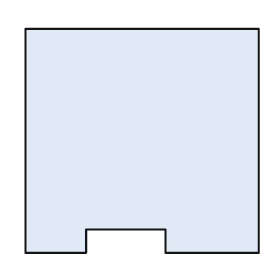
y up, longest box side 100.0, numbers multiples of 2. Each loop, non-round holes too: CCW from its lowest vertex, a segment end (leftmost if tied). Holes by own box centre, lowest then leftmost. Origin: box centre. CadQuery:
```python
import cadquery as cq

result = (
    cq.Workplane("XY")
    .moveTo(-50.0, -48.0)
    .lineTo(-24.0, -48.0)
    .lineTo(-24.0, -38.0)
    .lineTo(10.0, -38.0)
    .lineTo(10.0, -48.0)
    .lineTo(50.0, -48.0)
    .lineTo(50.0, 48.0)
    .lineTo(-50.0, 48.0)
    .close()
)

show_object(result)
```